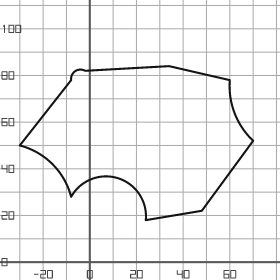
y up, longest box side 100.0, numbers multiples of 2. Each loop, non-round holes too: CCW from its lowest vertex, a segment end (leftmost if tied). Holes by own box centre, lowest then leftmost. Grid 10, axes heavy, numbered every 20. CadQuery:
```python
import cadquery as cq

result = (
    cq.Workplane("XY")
    .moveTo(24.0, 18.0)
    .lineTo(48.0, 22.0)
    .lineTo(70.0, 52.0)
    .threePointArc((62.0, 64.0), (60.0, 78.0))
    .lineTo(34.0, 84.0)
    .lineTo(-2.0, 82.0)
    .threePointArc((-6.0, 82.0), (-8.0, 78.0))
    .lineTo(-30.0, 50.0)
    .threePointArc((-16.0, 42.0), (-8.0, 28.0))
    .threePointArc((12.0, 36.0), (24.0, 18.0))
    .close()
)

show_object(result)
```